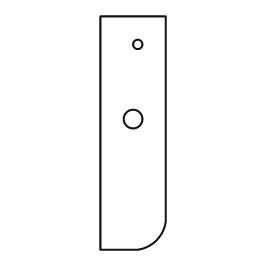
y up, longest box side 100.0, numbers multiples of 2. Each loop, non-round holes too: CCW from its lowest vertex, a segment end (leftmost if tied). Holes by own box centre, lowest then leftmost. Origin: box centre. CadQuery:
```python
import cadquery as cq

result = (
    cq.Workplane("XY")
    .moveTo(-14.0, -50.0)
    .lineTo(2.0, -50.0)
    .threePointArc((10.0, -46.0), (14.0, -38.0))
    .lineTo(14.0, 50.0)
    .lineTo(-14.0, 50.0)
    .close()
    .moveTo(0.0, 6.0)
    .circle(4.0)
    .moveTo(2.0, 38.0)
    .circle(2.0)
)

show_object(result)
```